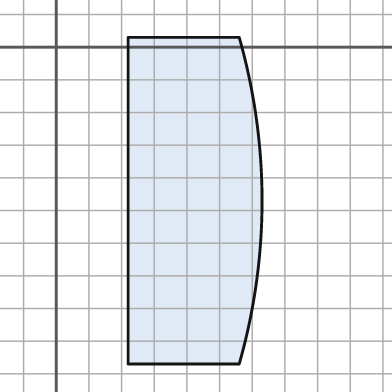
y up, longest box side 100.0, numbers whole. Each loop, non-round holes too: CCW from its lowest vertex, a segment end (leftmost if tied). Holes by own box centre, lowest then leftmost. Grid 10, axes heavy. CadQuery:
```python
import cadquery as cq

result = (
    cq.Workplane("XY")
    .moveTo(22.0, -97.0)
    .lineTo(56.0, -97.0)
    .threePointArc((63.0, -47.0), (56.0, 3.0))
    .lineTo(22.0, 3.0)
    .close()
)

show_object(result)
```